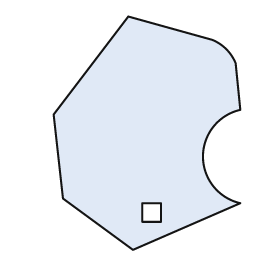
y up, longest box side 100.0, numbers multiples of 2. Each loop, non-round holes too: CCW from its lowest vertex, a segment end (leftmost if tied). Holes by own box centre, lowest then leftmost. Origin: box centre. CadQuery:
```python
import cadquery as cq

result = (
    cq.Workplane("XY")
    .moveTo(-6.0, -50.0)
    .lineTo(40.0, -30.0)
    .threePointArc((24.0, -10.0), (40.0, 10.0))
    .lineTo(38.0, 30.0)
    .threePointArc((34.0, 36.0), (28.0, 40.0))
    .lineTo(-8.0, 50.0)
    .lineTo(-40.0, 8.0)
    .lineTo(-36.0, -28.0)
    .close()
    .moveTo(-2.0, -38.0)
    .lineTo(6.0, -38.0)
    .lineTo(6.0, -30.0)
    .lineTo(-2.0, -30.0)
    .close()
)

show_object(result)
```